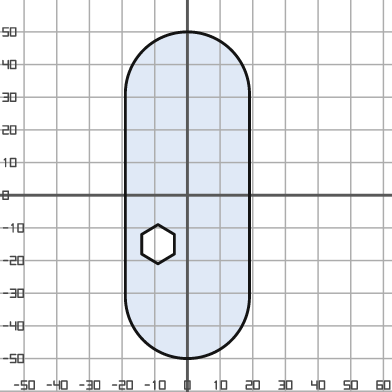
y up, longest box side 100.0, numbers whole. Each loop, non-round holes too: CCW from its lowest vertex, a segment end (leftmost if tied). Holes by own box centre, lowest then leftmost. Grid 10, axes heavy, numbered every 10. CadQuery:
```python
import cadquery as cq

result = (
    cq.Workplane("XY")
    .moveTo(-19.0, -31.0)
    .threePointArc((0.0, -50.0), (19.0, -31.0))
    .lineTo(19.0, 31.0)
    .threePointArc((0.0, 50.0), (-19.0, 31.0))
    .close()
    .moveTo(-9.0, -21.0)
    .lineTo(-4.0, -18.0)
    .lineTo(-4.0, -12.0)
    .lineTo(-9.0, -9.0)
    .lineTo(-14.0, -12.0)
    .lineTo(-14.0, -18.0)
    .close()
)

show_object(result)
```